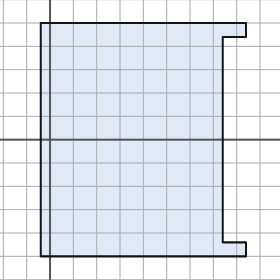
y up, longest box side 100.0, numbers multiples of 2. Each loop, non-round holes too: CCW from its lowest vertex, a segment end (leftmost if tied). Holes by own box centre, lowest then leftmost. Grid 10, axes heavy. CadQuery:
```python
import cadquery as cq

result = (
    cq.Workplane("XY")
    .moveTo(-4.0, -50.0)
    .lineTo(84.0, -50.0)
    .lineTo(84.0, -44.0)
    .lineTo(74.0, -44.0)
    .lineTo(74.0, 44.0)
    .lineTo(84.0, 44.0)
    .lineTo(84.0, 50.0)
    .lineTo(-4.0, 50.0)
    .close()
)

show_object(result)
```